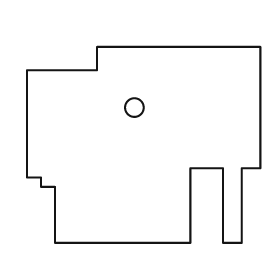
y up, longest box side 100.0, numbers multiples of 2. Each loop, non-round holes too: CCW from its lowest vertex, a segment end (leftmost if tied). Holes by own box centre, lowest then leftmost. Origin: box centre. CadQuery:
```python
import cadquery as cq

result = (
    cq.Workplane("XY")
    .moveTo(-38.0, -42.0)
    .lineTo(20.0, -42.0)
    .lineTo(20.0, -10.0)
    .lineTo(34.0, -10.0)
    .lineTo(34.0, -42.0)
    .lineTo(42.0, -42.0)
    .lineTo(42.0, -10.0)
    .lineTo(50.0, -10.0)
    .lineTo(50.0, 42.0)
    .lineTo(-20.0, 42.0)
    .lineTo(-20.0, 32.0)
    .lineTo(-50.0, 32.0)
    .lineTo(-50.0, -14.0)
    .lineTo(-44.0, -14.0)
    .lineTo(-44.0, -18.0)
    .lineTo(-38.0, -18.0)
    .close()
    .moveTo(-4.0, 16.0)
    .circle(4.0)
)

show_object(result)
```